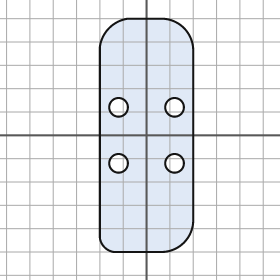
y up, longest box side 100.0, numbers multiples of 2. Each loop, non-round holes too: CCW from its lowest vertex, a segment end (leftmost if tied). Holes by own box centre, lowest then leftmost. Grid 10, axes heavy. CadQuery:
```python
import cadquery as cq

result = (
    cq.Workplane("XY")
    .moveTo(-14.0, -50.0)
    .lineTo(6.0, -50.0)
    .threePointArc((16.0, -46.0), (20.0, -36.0))
    .lineTo(20.0, 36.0)
    .threePointArc((16.0, 46.0), (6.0, 50.0))
    .lineTo(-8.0, 50.0)
    .threePointArc((-16.0, 46.0), (-20.0, 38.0))
    .lineTo(-20.0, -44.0)
    .threePointArc((-18.0, -48.0), (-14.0, -50.0))
    .close()
    .moveTo(-12.0, -12.0)
    .circle(4.0)
    .moveTo(12.0, -12.0)
    .circle(4.0)
    .moveTo(-12.0, 12.0)
    .circle(4.0)
    .moveTo(12.0, 12.0)
    .circle(4.0)
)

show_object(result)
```